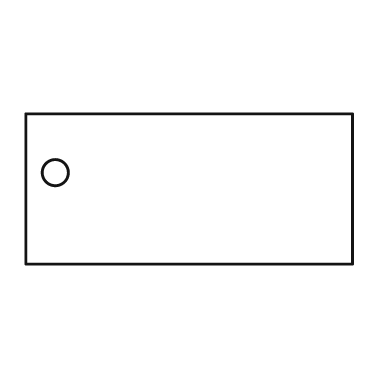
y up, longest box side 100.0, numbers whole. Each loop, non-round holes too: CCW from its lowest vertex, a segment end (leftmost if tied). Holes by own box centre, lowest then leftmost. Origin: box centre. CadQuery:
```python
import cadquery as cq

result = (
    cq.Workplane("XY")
    .moveTo(-50.0, -23.0)
    .lineTo(50.0, -23.0)
    .lineTo(50.0, 23.0)
    .lineTo(-50.0, 23.0)
    .close()
    .moveTo(-41.0, 5.0)
    .circle(4.0)
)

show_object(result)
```